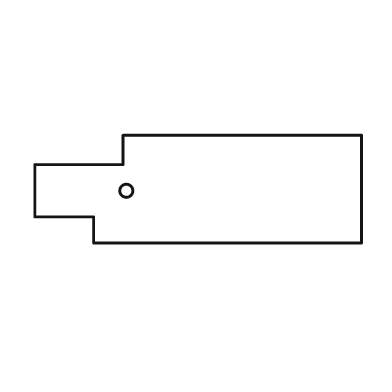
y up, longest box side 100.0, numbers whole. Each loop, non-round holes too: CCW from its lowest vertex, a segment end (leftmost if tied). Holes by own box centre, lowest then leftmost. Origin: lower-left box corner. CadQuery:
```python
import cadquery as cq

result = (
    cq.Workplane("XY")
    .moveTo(18.0, 0.0)
    .lineTo(100.0, 0.0)
    .lineTo(100.0, 33.0)
    .lineTo(27.0, 33.0)
    .lineTo(27.0, 24.0)
    .lineTo(0.0, 24.0)
    .lineTo(0.0, 8.0)
    .lineTo(18.0, 8.0)
    .close()
    .moveTo(28.0, 16.0)
    .circle(2.0)
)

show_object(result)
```